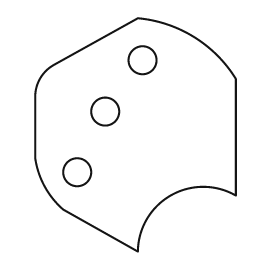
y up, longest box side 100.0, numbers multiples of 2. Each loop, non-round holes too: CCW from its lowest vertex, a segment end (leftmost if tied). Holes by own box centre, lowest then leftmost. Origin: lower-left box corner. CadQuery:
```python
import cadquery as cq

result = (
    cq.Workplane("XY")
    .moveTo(44.0, 0.0)
    .threePointArc((58.0, 24.0), (86.0, 24.0))
    .lineTo(86.0, 74.0)
    .threePointArc((68.0, 92.0), (44.0, 100.0))
    .lineTo(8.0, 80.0)
    .threePointArc((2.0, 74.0), (0.0, 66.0))
    .lineTo(0.0, 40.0)
    .threePointArc((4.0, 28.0), (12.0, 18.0))
    .close()
    .moveTo(18.0, 34.0)
    .circle(6.0)
    .moveTo(30.0, 60.0)
    .circle(6.0)
    .moveTo(46.0, 82.0)
    .circle(6.0)
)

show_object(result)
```